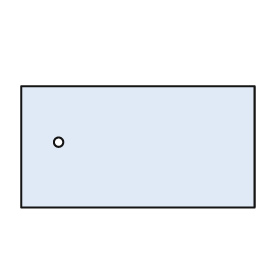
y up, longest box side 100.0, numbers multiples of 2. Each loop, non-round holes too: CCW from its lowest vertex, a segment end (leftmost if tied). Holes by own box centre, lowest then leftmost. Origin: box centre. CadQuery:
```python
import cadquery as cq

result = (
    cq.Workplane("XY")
    .moveTo(-50.0, -26.0)
    .lineTo(50.0, -26.0)
    .lineTo(50.0, 26.0)
    .lineTo(-50.0, 26.0)
    .close()
    .moveTo(-34.0, 2.0)
    .circle(2.0)
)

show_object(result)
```